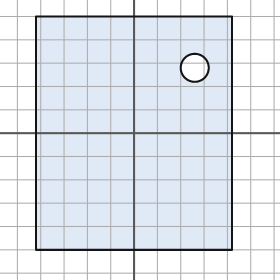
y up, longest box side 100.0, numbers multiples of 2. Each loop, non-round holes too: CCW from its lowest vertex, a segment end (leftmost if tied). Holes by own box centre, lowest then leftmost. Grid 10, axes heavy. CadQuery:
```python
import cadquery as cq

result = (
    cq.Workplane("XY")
    .moveTo(-42.0, -50.0)
    .lineTo(42.0, -50.0)
    .lineTo(42.0, 50.0)
    .lineTo(-42.0, 50.0)
    .close()
    .moveTo(26.0, 28.0)
    .circle(6.0)
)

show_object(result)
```